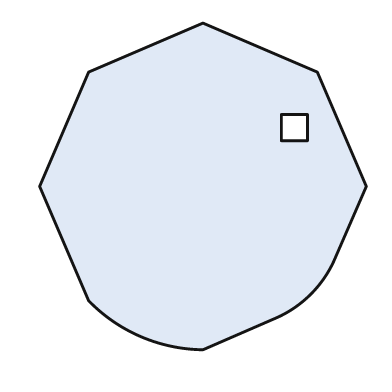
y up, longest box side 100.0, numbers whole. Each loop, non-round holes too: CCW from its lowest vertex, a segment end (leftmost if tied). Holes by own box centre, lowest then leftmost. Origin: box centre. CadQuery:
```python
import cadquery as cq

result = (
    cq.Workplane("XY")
    .moveTo(0.0, -50.0)
    .lineTo(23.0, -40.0)
    .threePointArc((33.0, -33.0), (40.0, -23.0))
    .lineTo(50.0, 0.0)
    .lineTo(35.0, 35.0)
    .lineTo(0.0, 50.0)
    .lineTo(-35.0, 35.0)
    .lineTo(-50.0, 0.0)
    .lineTo(-35.0, -35.0)
    .threePointArc((-19.0, -46.0), (0.0, -50.0))
    .close()
    .moveTo(24.0, 14.0)
    .lineTo(32.0, 14.0)
    .lineTo(32.0, 22.0)
    .lineTo(24.0, 22.0)
    .close()
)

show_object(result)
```